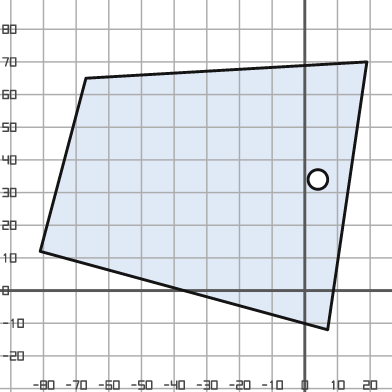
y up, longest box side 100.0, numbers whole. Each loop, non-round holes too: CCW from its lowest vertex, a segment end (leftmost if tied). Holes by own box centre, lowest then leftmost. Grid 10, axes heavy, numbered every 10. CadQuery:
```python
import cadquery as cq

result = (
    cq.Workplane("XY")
    .moveTo(7.0, -12.0)
    .lineTo(19.0, 70.0)
    .lineTo(-67.0, 65.0)
    .lineTo(-81.0, 12.0)
    .close()
    .moveTo(4.0, 34.0)
    .circle(3.0)
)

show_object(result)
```